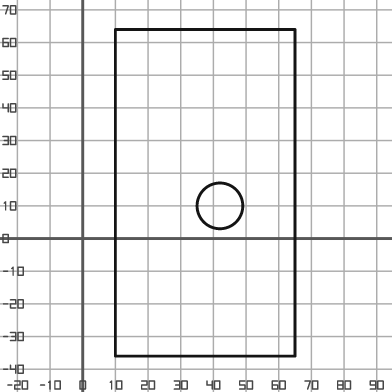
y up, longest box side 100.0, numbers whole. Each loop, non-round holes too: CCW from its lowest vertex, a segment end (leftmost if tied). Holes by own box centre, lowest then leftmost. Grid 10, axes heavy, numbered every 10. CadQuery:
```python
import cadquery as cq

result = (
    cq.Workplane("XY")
    .moveTo(10.0, -36.0)
    .lineTo(65.0, -36.0)
    .lineTo(65.0, 64.0)
    .lineTo(10.0, 64.0)
    .close()
    .moveTo(42.0, 10.0)
    .circle(7.0)
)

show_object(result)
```